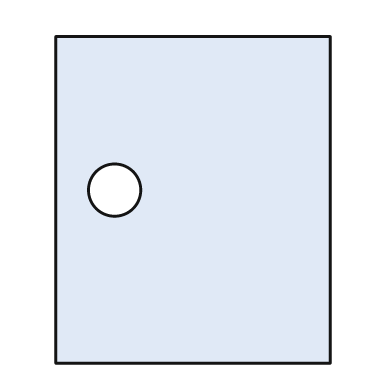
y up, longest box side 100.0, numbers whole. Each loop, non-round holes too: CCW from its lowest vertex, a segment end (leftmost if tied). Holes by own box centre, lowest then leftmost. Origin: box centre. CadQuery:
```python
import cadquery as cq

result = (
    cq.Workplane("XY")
    .moveTo(-42.0, -50.0)
    .lineTo(42.0, -50.0)
    .lineTo(42.0, 50.0)
    .lineTo(-42.0, 50.0)
    .close()
    .moveTo(-24.0, 3.0)
    .circle(8.0)
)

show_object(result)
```